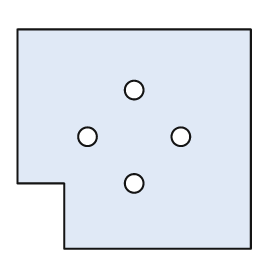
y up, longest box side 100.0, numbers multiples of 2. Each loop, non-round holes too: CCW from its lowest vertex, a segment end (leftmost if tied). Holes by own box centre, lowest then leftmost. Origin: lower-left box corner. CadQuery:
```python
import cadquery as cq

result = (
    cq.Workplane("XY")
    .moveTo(20.0, 0.0)
    .lineTo(100.0, 0.0)
    .lineTo(100.0, 94.0)
    .lineTo(0.0, 94.0)
    .lineTo(0.0, 28.0)
    .lineTo(20.0, 28.0)
    .close()
    .moveTo(50.0, 28.0)
    .circle(4.0)
    .moveTo(30.0, 48.0)
    .circle(4.0)
    .moveTo(70.0, 48.0)
    .circle(4.0)
    .moveTo(50.0, 68.0)
    .circle(4.0)
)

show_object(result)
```